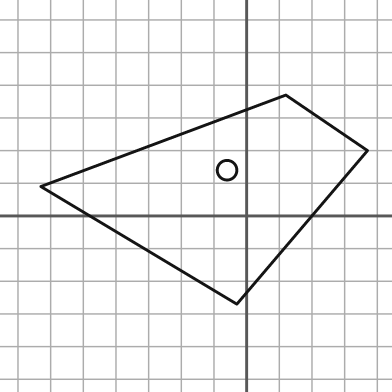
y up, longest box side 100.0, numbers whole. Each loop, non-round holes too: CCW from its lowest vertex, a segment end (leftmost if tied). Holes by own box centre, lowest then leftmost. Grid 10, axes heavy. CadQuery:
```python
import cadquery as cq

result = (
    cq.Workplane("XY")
    .moveTo(-3.0, -27.0)
    .lineTo(37.0, 20.0)
    .lineTo(12.0, 37.0)
    .lineTo(-63.0, 9.0)
    .close()
    .moveTo(-6.0, 14.0)
    .circle(3.0)
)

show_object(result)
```